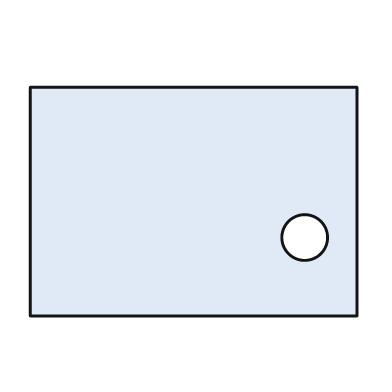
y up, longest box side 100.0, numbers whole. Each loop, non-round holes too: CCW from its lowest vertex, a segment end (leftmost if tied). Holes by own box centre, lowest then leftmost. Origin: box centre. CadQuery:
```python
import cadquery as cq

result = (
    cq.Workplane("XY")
    .moveTo(-50.0, -35.0)
    .lineTo(50.0, -35.0)
    .lineTo(50.0, 35.0)
    .lineTo(-50.0, 35.0)
    .close()
    .moveTo(34.0, -11.0)
    .circle(7.0)
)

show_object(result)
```